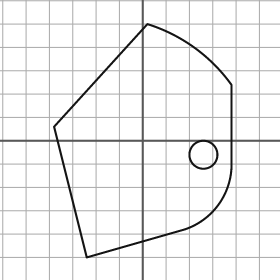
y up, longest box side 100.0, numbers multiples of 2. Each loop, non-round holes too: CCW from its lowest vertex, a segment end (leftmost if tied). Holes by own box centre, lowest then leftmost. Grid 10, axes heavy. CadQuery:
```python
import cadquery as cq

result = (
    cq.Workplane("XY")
    .moveTo(-24.0, -50.0)
    .lineTo(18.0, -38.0)
    .threePointArc((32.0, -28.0), (38.0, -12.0))
    .lineTo(38.0, 24.0)
    .threePointArc((22.0, 40.0), (2.0, 50.0))
    .lineTo(-38.0, 6.0)
    .close()
    .moveTo(26.0, -6.0)
    .circle(6.0)
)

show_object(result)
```